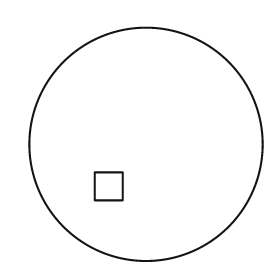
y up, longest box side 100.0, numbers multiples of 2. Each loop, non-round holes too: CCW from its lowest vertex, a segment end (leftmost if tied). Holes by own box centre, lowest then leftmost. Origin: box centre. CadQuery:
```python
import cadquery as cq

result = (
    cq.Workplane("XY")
    .moveTo(0.0, 0.0)
    .circle(50.0)
    .moveTo(-22.0, -24.0)
    .lineTo(-10.0, -24.0)
    .lineTo(-10.0, -12.0)
    .lineTo(-22.0, -12.0)
    .close()
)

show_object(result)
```